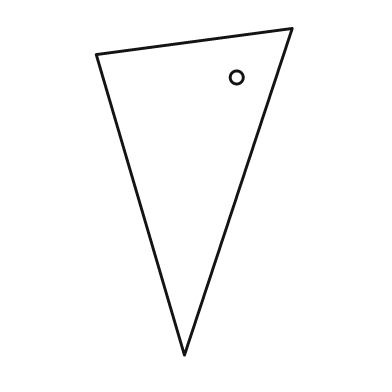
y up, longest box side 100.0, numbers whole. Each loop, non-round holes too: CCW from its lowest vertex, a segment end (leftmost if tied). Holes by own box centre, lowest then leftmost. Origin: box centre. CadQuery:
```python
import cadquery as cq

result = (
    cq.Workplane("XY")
    .moveTo(-3.0, -50.0)
    .lineTo(30.0, 50.0)
    .lineTo(-30.0, 42.0)
    .close()
    .moveTo(13.0, 35.0)
    .circle(2.0)
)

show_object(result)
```